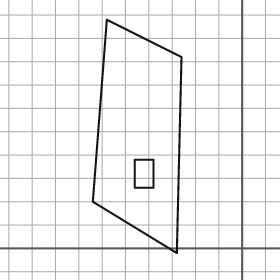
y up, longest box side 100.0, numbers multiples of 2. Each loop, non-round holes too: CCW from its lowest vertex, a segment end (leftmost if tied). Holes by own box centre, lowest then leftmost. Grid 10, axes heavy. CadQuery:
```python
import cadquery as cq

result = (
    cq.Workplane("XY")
    .moveTo(-28.0, -2.0)
    .lineTo(-26.0, 82.0)
    .lineTo(-58.0, 98.0)
    .lineTo(-64.0, 20.0)
    .close()
    .moveTo(-46.0, 26.0)
    .lineTo(-38.0, 26.0)
    .lineTo(-38.0, 38.0)
    .lineTo(-46.0, 38.0)
    .close()
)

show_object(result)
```